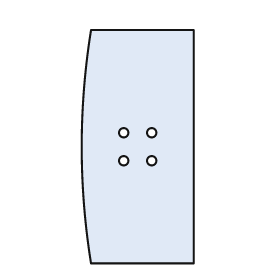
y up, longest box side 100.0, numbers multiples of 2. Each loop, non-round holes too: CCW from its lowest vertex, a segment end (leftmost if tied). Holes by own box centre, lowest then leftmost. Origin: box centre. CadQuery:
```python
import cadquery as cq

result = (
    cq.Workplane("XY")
    .moveTo(-20.0, -50.0)
    .lineTo(24.0, -50.0)
    .lineTo(24.0, 50.0)
    .lineTo(-20.0, 50.0)
    .threePointArc((-24.0, 0.0), (-20.0, -50.0))
    .close()
    .moveTo(-6.0, -6.0)
    .circle(2.0)
    .moveTo(6.0, -6.0)
    .circle(2.0)
    .moveTo(-6.0, 6.0)
    .circle(2.0)
    .moveTo(6.0, 6.0)
    .circle(2.0)
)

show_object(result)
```